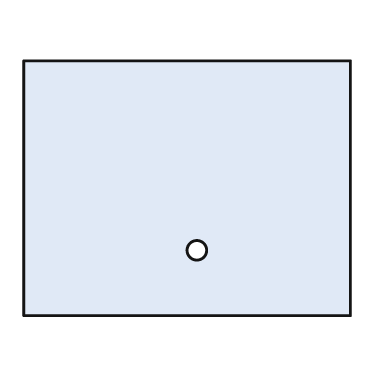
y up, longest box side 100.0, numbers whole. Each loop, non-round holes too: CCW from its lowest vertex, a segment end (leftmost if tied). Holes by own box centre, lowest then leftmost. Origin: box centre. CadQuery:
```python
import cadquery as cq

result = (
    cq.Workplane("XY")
    .moveTo(-50.0, -39.0)
    .lineTo(50.0, -39.0)
    .lineTo(50.0, 39.0)
    .lineTo(-50.0, 39.0)
    .close()
    .moveTo(3.0, -19.0)
    .circle(3.0)
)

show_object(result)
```